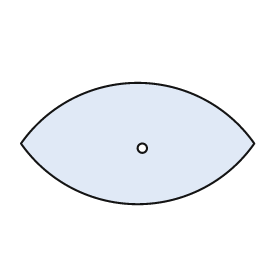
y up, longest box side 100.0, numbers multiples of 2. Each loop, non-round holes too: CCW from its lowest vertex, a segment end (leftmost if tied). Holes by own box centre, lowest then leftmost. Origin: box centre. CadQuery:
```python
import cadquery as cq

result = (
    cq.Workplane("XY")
    .moveTo(-50.0, 0.0)
    .threePointArc((0.0, -26.0), (50.0, 0.0))
    .threePointArc((0.0, 26.0), (-50.0, 0.0))
    .close()
    .moveTo(2.0, -2.0)
    .circle(2.0)
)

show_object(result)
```